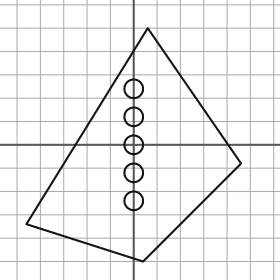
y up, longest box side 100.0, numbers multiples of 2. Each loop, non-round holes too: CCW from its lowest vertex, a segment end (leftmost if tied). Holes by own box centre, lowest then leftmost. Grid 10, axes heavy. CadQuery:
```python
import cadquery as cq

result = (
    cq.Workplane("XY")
    .moveTo(4.0, -50.0)
    .lineTo(46.0, -8.0)
    .lineTo(6.0, 50.0)
    .lineTo(-46.0, -34.0)
    .close()
    .moveTo(0.0, -24.0)
    .circle(4.0)
    .moveTo(0.0, -12.0)
    .circle(4.0)
    .moveTo(0.0, 0.0)
    .circle(4.0)
    .moveTo(0.0, 12.0)
    .circle(4.0)
    .moveTo(0.0, 24.0)
    .circle(4.0)
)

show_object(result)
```